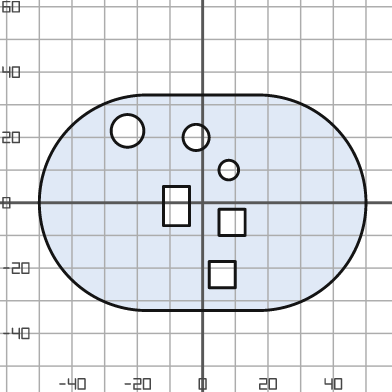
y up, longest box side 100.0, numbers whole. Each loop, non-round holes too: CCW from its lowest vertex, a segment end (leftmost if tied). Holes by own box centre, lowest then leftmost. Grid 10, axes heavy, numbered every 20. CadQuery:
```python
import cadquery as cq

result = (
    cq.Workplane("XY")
    .moveTo(-17.0, -33.0)
    .lineTo(17.0, -33.0)
    .threePointArc((50.0, 0.0), (17.0, 33.0))
    .lineTo(-17.0, 33.0)
    .threePointArc((-50.0, 0.0), (-17.0, -33.0))
    .close()
    .moveTo(2.0, -26.0)
    .lineTo(10.0, -26.0)
    .lineTo(10.0, -18.0)
    .lineTo(2.0, -18.0)
    .close()
    .moveTo(5.0, -10.0)
    .lineTo(13.0, -10.0)
    .lineTo(13.0, -2.0)
    .lineTo(5.0, -2.0)
    .close()
    .moveTo(-12.0, -7.0)
    .lineTo(-4.0, -7.0)
    .lineTo(-4.0, 5.0)
    .lineTo(-12.0, 5.0)
    .close()
    .moveTo(8.0, 10.0)
    .circle(3.0)
    .moveTo(-2.0, 20.0)
    .circle(4.0)
    .moveTo(-23.0, 22.0)
    .circle(5.0)
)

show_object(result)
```